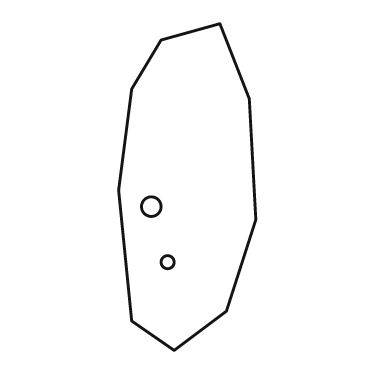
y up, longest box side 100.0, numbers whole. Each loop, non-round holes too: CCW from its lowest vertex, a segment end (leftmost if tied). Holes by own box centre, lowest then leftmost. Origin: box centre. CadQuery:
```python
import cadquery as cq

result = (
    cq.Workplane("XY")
    .moveTo(-4.0, -50.0)
    .lineTo(12.0, -38.0)
    .lineTo(21.0, -10.0)
    .lineTo(19.0, 27.0)
    .lineTo(10.0, 50.0)
    .lineTo(-8.0, 45.0)
    .lineTo(-17.0, 30.0)
    .lineTo(-21.0, -1.0)
    .lineTo(-17.0, -41.0)
    .close()
    .moveTo(-6.0, -23.0)
    .circle(2.0)
    .moveTo(-11.0, -6.0)
    .circle(3.0)
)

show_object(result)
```